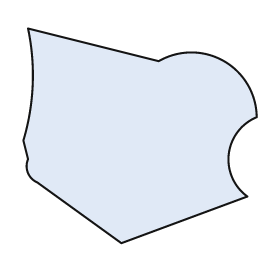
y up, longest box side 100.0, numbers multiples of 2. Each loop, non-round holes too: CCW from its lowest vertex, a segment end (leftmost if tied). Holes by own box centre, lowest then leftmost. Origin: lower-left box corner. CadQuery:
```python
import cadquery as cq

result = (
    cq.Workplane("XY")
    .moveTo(42.0, 0.0)
    .lineTo(96.0, 20.0)
    .threePointArc((88.0, 38.0), (100.0, 54.0))
    .threePointArc((86.0, 78.0), (58.0, 78.0))
    .lineTo(2.0, 92.0)
    .threePointArc((4.0, 68.0), (0.0, 44.0))
    .lineTo(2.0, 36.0)
    .threePointArc((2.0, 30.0), (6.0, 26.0))
    .close()
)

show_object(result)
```